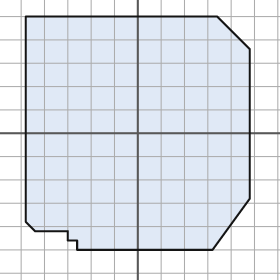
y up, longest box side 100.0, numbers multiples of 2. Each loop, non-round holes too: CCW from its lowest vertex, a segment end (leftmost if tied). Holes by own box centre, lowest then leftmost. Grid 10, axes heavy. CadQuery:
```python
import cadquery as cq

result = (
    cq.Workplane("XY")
    .moveTo(-26.0, -50.0)
    .lineTo(32.0, -50.0)
    .lineTo(48.0, -28.0)
    .lineTo(48.0, 36.0)
    .lineTo(34.0, 50.0)
    .lineTo(-48.0, 50.0)
    .lineTo(-48.0, -38.0)
    .lineTo(-44.0, -42.0)
    .lineTo(-30.0, -42.0)
    .lineTo(-30.0, -46.0)
    .lineTo(-26.0, -46.0)
    .close()
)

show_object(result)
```